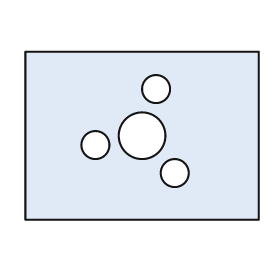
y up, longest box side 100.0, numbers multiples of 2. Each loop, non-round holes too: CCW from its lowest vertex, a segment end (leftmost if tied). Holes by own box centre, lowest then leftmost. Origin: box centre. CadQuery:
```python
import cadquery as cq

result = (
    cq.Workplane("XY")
    .moveTo(-50.0, -36.0)
    .lineTo(50.0, -36.0)
    .lineTo(50.0, 36.0)
    .lineTo(-50.0, 36.0)
    .close()
    .moveTo(14.0, -16.0)
    .circle(6.0)
    .moveTo(-20.0, -4.0)
    .circle(6.0)
    .moveTo(0.0, 0.0)
    .circle(10.0)
    .moveTo(6.0, 20.0)
    .circle(6.0)
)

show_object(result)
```